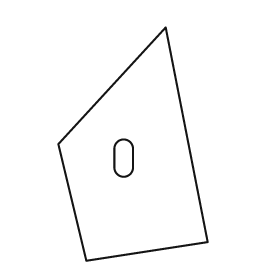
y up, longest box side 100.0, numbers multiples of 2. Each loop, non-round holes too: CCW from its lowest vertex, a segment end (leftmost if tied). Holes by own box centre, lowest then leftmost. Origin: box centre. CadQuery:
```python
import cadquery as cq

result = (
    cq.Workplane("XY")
    .moveTo(-20.0, -50.0)
    .lineTo(32.0, -42.0)
    .lineTo(14.0, 50.0)
    .lineTo(-32.0, 0.0)
    .close()
    .moveTo(-8.0, -10.0)
    .threePointArc((-4.0, -14.0), (0.0, -10.0))
    .lineTo(0.0, -2.0)
    .threePointArc((-4.0, 2.0), (-8.0, -2.0))
    .close()
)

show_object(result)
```